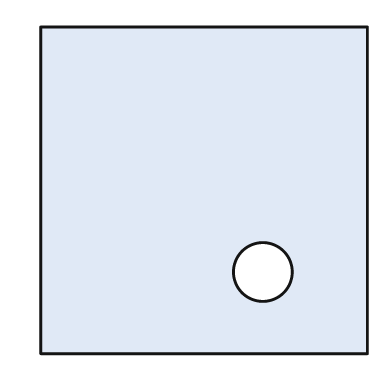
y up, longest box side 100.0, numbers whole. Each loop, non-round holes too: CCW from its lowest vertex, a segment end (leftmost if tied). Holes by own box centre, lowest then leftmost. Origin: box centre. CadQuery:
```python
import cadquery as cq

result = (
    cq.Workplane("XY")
    .moveTo(-50.0, -50.0)
    .lineTo(50.0, -50.0)
    .lineTo(50.0, 50.0)
    .lineTo(-50.0, 50.0)
    .close()
    .moveTo(18.0, -25.0)
    .circle(9.0)
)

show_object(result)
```